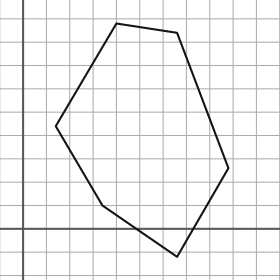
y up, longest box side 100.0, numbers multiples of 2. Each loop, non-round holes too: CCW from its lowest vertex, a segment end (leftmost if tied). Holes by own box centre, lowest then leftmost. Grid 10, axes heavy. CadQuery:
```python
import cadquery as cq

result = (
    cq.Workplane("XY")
    .moveTo(66.0, -12.0)
    .lineTo(88.0, 26.0)
    .lineTo(66.0, 84.0)
    .lineTo(40.0, 88.0)
    .lineTo(14.0, 44.0)
    .lineTo(34.0, 10.0)
    .close()
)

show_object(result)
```